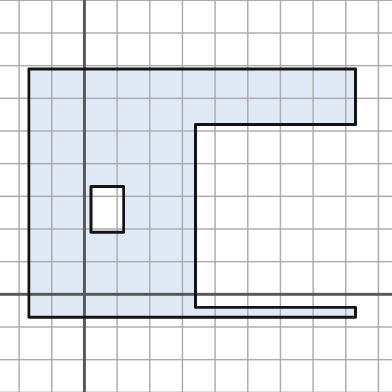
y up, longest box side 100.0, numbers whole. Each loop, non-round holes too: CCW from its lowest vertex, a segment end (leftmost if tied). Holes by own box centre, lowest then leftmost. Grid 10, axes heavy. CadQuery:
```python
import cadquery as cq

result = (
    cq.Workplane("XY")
    .moveTo(-17.0, -7.0)
    .lineTo(83.0, -7.0)
    .lineTo(83.0, -4.0)
    .lineTo(34.0, -4.0)
    .lineTo(34.0, 52.0)
    .lineTo(83.0, 52.0)
    .lineTo(83.0, 69.0)
    .lineTo(-17.0, 69.0)
    .close()
    .moveTo(2.0, 19.0)
    .lineTo(12.0, 19.0)
    .lineTo(12.0, 33.0)
    .lineTo(2.0, 33.0)
    .close()
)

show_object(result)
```